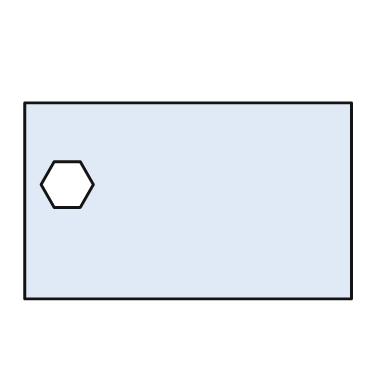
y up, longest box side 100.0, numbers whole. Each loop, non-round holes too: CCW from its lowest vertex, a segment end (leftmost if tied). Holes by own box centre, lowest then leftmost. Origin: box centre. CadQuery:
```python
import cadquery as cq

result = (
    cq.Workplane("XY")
    .moveTo(-50.0, -30.0)
    .lineTo(50.0, -30.0)
    .lineTo(50.0, 30.0)
    .lineTo(-50.0, 30.0)
    .close()
    .moveTo(-41.0, -2.0)
    .lineTo(-33.0, -2.0)
    .lineTo(-29.0, 5.0)
    .lineTo(-33.0, 12.0)
    .lineTo(-41.0, 12.0)
    .lineTo(-45.0, 5.0)
    .close()
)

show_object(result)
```